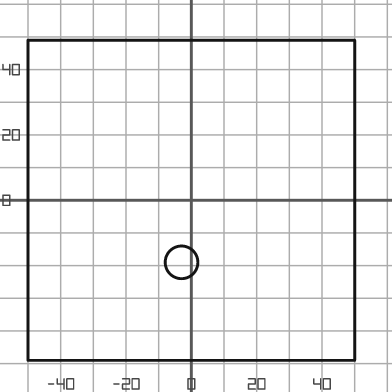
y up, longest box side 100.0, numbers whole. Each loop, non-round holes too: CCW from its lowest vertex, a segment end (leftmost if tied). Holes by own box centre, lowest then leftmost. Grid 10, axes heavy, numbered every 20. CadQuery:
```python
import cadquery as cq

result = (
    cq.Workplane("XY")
    .moveTo(-50.0, -49.0)
    .lineTo(50.0, -49.0)
    .lineTo(50.0, 49.0)
    .lineTo(-50.0, 49.0)
    .close()
    .moveTo(-3.0, -19.0)
    .circle(5.0)
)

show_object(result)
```